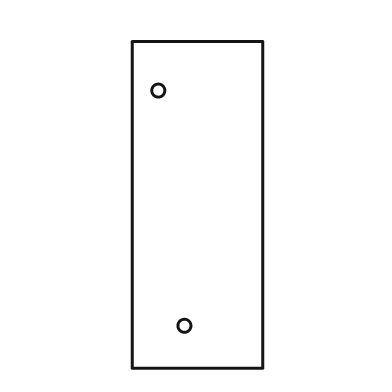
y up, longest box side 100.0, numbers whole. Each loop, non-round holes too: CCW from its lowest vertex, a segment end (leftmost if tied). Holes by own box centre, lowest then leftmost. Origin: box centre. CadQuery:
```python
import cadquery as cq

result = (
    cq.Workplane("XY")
    .moveTo(-20.0, -50.0)
    .lineTo(20.0, -50.0)
    .lineTo(20.0, 50.0)
    .lineTo(-20.0, 50.0)
    .close()
    .moveTo(-4.0, -37.0)
    .circle(2.0)
    .moveTo(-12.0, 35.0)
    .circle(2.0)
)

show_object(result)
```